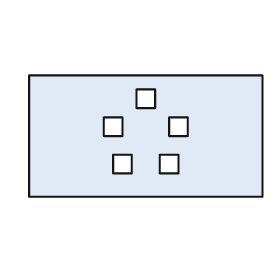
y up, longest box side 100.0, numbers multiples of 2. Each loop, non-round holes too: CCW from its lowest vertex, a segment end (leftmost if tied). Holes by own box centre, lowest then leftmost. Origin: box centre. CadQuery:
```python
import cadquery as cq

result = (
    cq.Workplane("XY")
    .moveTo(-50.0, -26.0)
    .lineTo(50.0, -26.0)
    .lineTo(50.0, 26.0)
    .lineTo(-50.0, 26.0)
    .close()
    .moveTo(-14.0, -16.0)
    .lineTo(-6.0, -16.0)
    .lineTo(-6.0, -8.0)
    .lineTo(-14.0, -8.0)
    .close()
    .moveTo(6.0, -16.0)
    .lineTo(14.0, -16.0)
    .lineTo(14.0, -8.0)
    .lineTo(6.0, -8.0)
    .close()
    .moveTo(-18.0, 0.0)
    .lineTo(-10.0, 0.0)
    .lineTo(-10.0, 8.0)
    .lineTo(-18.0, 8.0)
    .close()
    .moveTo(10.0, 0.0)
    .lineTo(18.0, 0.0)
    .lineTo(18.0, 8.0)
    .lineTo(10.0, 8.0)
    .close()
    .moveTo(-4.0, 12.0)
    .lineTo(4.0, 12.0)
    .lineTo(4.0, 20.0)
    .lineTo(-4.0, 20.0)
    .close()
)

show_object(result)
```